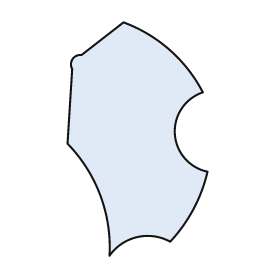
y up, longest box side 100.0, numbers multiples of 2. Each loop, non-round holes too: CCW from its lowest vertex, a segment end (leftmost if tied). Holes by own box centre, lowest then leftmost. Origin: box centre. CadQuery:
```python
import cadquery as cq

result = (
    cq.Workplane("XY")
    .moveTo(-12.0, -50.0)
    .threePointArc((0.0, -42.0), (14.0, -44.0))
    .threePointArc((24.0, -30.0), (30.0, -14.0))
    .threePointArc((16.0, 2.0), (28.0, 20.0))
    .threePointArc((14.0, 38.0), (-6.0, 50.0))
    .lineTo(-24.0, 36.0)
    .threePointArc((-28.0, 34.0), (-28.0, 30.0))
    .lineTo(-30.0, -2.0)
    .threePointArc((-16.0, -24.0), (-12.0, -50.0))
    .close()
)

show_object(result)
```